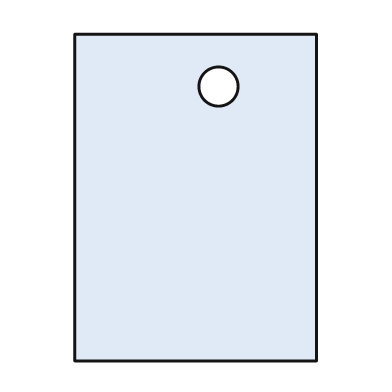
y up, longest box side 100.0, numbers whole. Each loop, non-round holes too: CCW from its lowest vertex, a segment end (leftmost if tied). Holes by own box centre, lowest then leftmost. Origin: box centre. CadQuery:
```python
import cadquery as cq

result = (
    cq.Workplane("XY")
    .moveTo(-37.0, -50.0)
    .lineTo(37.0, -50.0)
    .lineTo(37.0, 50.0)
    .lineTo(-37.0, 50.0)
    .close()
    .moveTo(7.0, 34.0)
    .circle(6.0)
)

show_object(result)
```